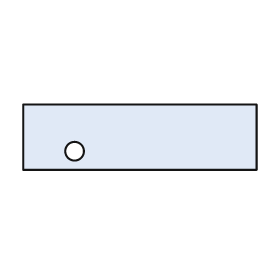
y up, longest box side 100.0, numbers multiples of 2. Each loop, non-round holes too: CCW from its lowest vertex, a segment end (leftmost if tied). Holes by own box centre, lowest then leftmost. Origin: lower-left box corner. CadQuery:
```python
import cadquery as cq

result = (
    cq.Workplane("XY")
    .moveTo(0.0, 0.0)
    .lineTo(100.0, 0.0)
    .lineTo(100.0, 28.0)
    .lineTo(0.0, 28.0)
    .close()
    .moveTo(22.0, 8.0)
    .circle(4.0)
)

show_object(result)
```